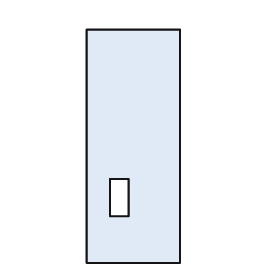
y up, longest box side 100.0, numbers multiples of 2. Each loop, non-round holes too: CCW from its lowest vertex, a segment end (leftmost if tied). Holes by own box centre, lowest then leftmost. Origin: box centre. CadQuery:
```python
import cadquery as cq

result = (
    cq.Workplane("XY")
    .moveTo(-20.0, -50.0)
    .lineTo(20.0, -50.0)
    .lineTo(20.0, 50.0)
    .lineTo(-20.0, 50.0)
    .close()
    .moveTo(-10.0, -30.0)
    .lineTo(-2.0, -30.0)
    .lineTo(-2.0, -14.0)
    .lineTo(-10.0, -14.0)
    .close()
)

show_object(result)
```